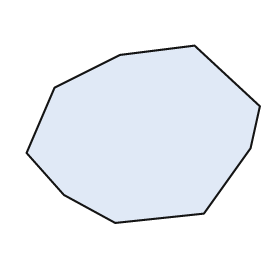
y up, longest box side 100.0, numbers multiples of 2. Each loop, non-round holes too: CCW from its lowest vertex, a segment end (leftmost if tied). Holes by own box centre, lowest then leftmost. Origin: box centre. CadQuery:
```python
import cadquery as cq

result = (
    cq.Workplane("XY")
    .moveTo(-12.0, -38.0)
    .lineTo(26.0, -34.0)
    .lineTo(46.0, -6.0)
    .lineTo(50.0, 12.0)
    .lineTo(22.0, 38.0)
    .lineTo(-10.0, 34.0)
    .lineTo(-38.0, 20.0)
    .lineTo(-50.0, -8.0)
    .lineTo(-34.0, -26.0)
    .close()
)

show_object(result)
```